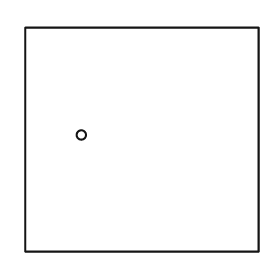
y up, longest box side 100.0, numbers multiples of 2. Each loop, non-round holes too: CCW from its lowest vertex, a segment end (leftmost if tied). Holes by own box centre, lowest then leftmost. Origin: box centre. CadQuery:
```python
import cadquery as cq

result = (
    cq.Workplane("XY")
    .moveTo(-50.0, -48.0)
    .lineTo(50.0, -48.0)
    .lineTo(50.0, 48.0)
    .lineTo(-50.0, 48.0)
    .close()
    .moveTo(-26.0, 2.0)
    .circle(2.0)
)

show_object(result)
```